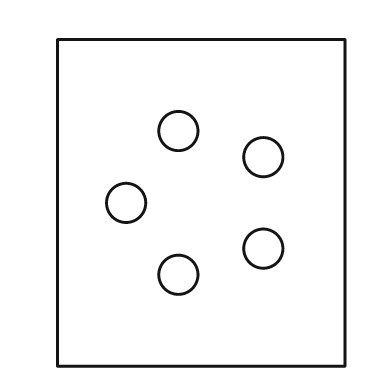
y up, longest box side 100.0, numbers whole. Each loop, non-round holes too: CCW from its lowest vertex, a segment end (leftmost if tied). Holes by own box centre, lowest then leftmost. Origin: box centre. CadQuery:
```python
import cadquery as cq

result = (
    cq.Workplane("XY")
    .moveTo(-44.0, -50.0)
    .lineTo(44.0, -50.0)
    .lineTo(44.0, 50.0)
    .lineTo(-44.0, 50.0)
    .close()
    .moveTo(-7.0, -22.0)
    .circle(6.0)
    .moveTo(19.0, -14.0)
    .circle(6.0)
    .moveTo(-23.0, 0.0)
    .circle(6.0)
    .moveTo(19.0, 14.0)
    .circle(6.0)
    .moveTo(-7.0, 22.0)
    .circle(6.0)
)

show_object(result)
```